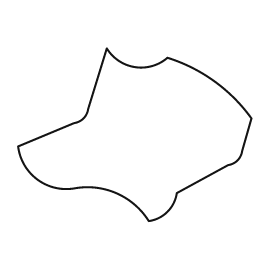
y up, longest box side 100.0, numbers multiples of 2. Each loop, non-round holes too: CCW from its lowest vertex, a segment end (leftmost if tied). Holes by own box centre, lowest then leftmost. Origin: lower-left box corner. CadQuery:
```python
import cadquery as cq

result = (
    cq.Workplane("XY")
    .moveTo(56.0, 0.0)
    .threePointArc((64.0, 4.0), (68.0, 12.0))
    .lineTo(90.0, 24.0)
    .threePointArc((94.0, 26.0), (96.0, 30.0))
    .lineTo(100.0, 44.0)
    .threePointArc((84.0, 60.0), (64.0, 70.0))
    .threePointArc((50.0, 66.0), (38.0, 74.0))
    .lineTo(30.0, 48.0)
    .threePointArc((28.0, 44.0), (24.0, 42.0))
    .lineTo(0.0, 32.0)
    .threePointArc((8.0, 18.0), (24.0, 14.0))
    .threePointArc((42.0, 12.0), (56.0, 0.0))
    .close()
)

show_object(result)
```